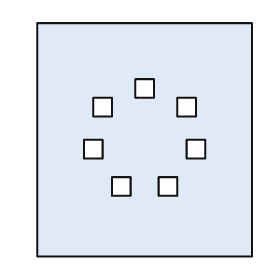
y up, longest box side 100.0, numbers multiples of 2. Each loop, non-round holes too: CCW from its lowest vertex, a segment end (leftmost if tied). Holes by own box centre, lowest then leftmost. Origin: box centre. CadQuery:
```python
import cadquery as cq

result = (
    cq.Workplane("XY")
    .moveTo(-46.0, -50.0)
    .lineTo(46.0, -50.0)
    .lineTo(46.0, 50.0)
    .lineTo(-46.0, 50.0)
    .close()
    .moveTo(-14.0, -24.0)
    .lineTo(-6.0, -24.0)
    .lineTo(-6.0, -16.0)
    .lineTo(-14.0, -16.0)
    .close()
    .moveTo(6.0, -24.0)
    .lineTo(14.0, -24.0)
    .lineTo(14.0, -16.0)
    .lineTo(6.0, -16.0)
    .close()
    .moveTo(-26.0, -8.0)
    .lineTo(-18.0, -8.0)
    .lineTo(-18.0, 0.0)
    .lineTo(-26.0, 0.0)
    .close()
    .moveTo(18.0, -8.0)
    .lineTo(26.0, -8.0)
    .lineTo(26.0, 0.0)
    .lineTo(18.0, 0.0)
    .close()
    .moveTo(-22.0, 10.0)
    .lineTo(-14.0, 10.0)
    .lineTo(-14.0, 18.0)
    .lineTo(-22.0, 18.0)
    .close()
    .moveTo(14.0, 10.0)
    .lineTo(22.0, 10.0)
    .lineTo(22.0, 18.0)
    .lineTo(14.0, 18.0)
    .close()
    .moveTo(-4.0, 18.0)
    .lineTo(4.0, 18.0)
    .lineTo(4.0, 26.0)
    .lineTo(-4.0, 26.0)
    .close()
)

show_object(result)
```